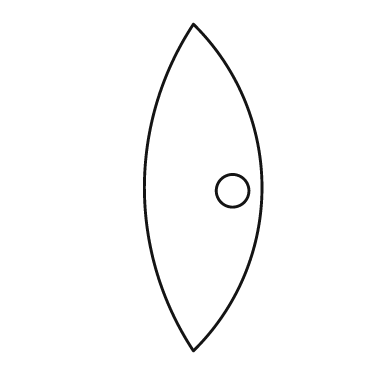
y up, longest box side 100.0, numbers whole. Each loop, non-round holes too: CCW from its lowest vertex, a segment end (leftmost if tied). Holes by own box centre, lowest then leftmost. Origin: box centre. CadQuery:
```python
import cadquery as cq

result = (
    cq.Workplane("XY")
    .moveTo(-3.0, -50.0)
    .threePointArc((18.0, 0.0), (-3.0, 50.0))
    .threePointArc((-18.0, 0.0), (-3.0, -50.0))
    .close()
    .moveTo(9.0, -1.0)
    .circle(5.0)
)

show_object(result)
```